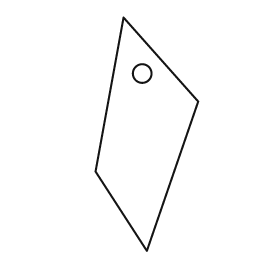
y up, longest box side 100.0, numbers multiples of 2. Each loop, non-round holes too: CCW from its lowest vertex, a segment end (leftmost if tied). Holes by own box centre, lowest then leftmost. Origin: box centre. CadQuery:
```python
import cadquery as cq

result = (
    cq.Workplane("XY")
    .moveTo(0.0, -50.0)
    .lineTo(22.0, 14.0)
    .lineTo(-10.0, 50.0)
    .lineTo(-22.0, -16.0)
    .close()
    .moveTo(-2.0, 26.0)
    .circle(4.0)
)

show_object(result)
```